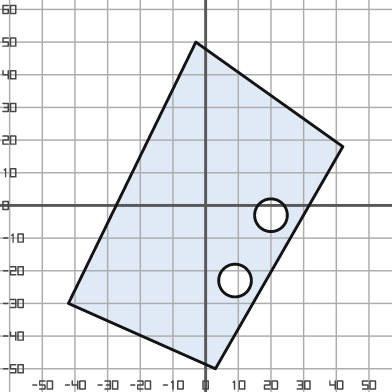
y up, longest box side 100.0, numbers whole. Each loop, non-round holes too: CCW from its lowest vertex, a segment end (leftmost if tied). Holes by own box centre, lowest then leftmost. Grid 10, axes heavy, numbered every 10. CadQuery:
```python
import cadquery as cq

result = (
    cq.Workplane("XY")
    .moveTo(3.0, -50.0)
    .lineTo(42.0, 18.0)
    .lineTo(-3.0, 50.0)
    .lineTo(-42.0, -30.0)
    .close()
    .moveTo(9.0, -23.0)
    .circle(5.0)
    .moveTo(20.0, -3.0)
    .circle(5.0)
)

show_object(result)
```